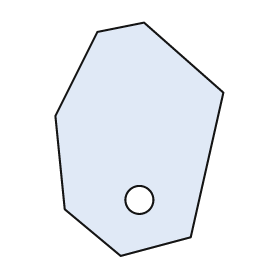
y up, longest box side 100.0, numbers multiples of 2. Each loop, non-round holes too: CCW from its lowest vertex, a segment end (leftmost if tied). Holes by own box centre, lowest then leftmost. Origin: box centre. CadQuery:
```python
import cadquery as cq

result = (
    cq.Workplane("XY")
    .moveTo(-8.0, -50.0)
    .lineTo(22.0, -42.0)
    .lineTo(36.0, 20.0)
    .lineTo(2.0, 50.0)
    .lineTo(-18.0, 46.0)
    .lineTo(-36.0, 10.0)
    .lineTo(-32.0, -30.0)
    .close()
    .moveTo(0.0, -26.0)
    .circle(6.0)
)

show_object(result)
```